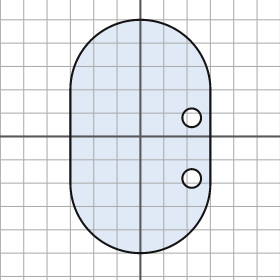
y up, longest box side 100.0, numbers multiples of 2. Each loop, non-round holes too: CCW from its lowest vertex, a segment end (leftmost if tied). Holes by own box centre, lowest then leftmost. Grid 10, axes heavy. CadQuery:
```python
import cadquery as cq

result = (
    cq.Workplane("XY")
    .moveTo(-30.0, -20.0)
    .threePointArc((0.0, -50.0), (30.0, -20.0))
    .lineTo(30.0, 20.0)
    .threePointArc((0.0, 50.0), (-30.0, 20.0))
    .close()
    .moveTo(22.0, -18.0)
    .circle(4.0)
    .moveTo(22.0, 8.0)
    .circle(4.0)
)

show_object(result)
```